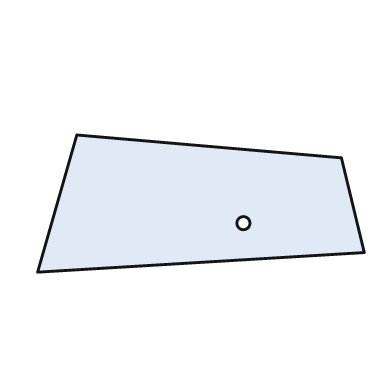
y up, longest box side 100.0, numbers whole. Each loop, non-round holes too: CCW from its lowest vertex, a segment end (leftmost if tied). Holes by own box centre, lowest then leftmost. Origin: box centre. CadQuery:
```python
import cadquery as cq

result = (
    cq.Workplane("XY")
    .moveTo(-50.0, -21.0)
    .lineTo(50.0, -15.0)
    .lineTo(43.0, 14.0)
    .lineTo(-38.0, 21.0)
    .close()
    .moveTo(13.0, -6.0)
    .circle(2.0)
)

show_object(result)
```